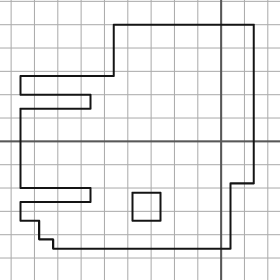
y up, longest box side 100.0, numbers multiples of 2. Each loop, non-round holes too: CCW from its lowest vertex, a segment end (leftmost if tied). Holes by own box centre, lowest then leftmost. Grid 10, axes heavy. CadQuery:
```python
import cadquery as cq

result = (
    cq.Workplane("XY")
    .moveTo(-72.0, -46.0)
    .lineTo(4.0, -46.0)
    .lineTo(4.0, -18.0)
    .lineTo(14.0, -18.0)
    .lineTo(14.0, 50.0)
    .lineTo(-46.0, 50.0)
    .lineTo(-46.0, 28.0)
    .lineTo(-86.0, 28.0)
    .lineTo(-86.0, 20.0)
    .lineTo(-56.0, 20.0)
    .lineTo(-56.0, 14.0)
    .lineTo(-86.0, 14.0)
    .lineTo(-86.0, -20.0)
    .lineTo(-56.0, -20.0)
    .lineTo(-56.0, -26.0)
    .lineTo(-86.0, -26.0)
    .lineTo(-86.0, -34.0)
    .lineTo(-78.0, -34.0)
    .lineTo(-78.0, -42.0)
    .lineTo(-72.0, -42.0)
    .close()
    .moveTo(-38.0, -34.0)
    .lineTo(-26.0, -34.0)
    .lineTo(-26.0, -22.0)
    .lineTo(-38.0, -22.0)
    .close()
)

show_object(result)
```